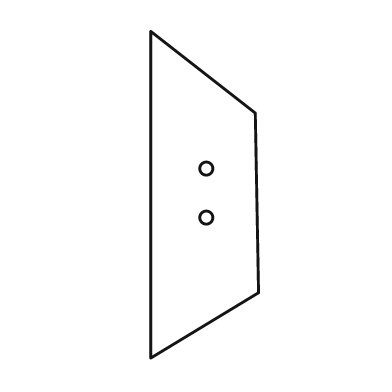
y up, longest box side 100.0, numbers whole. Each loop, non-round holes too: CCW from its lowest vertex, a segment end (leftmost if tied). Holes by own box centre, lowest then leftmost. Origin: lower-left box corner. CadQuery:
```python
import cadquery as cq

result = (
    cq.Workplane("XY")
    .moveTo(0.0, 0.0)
    .lineTo(33.0, 20.0)
    .lineTo(32.0, 75.0)
    .lineTo(0.0, 100.0)
    .close()
    .moveTo(17.0, 43.0)
    .circle(2.0)
    .moveTo(17.0, 58.0)
    .circle(2.0)
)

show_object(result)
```